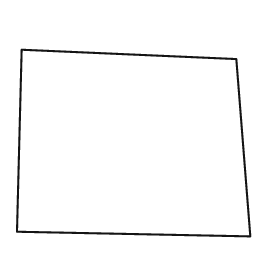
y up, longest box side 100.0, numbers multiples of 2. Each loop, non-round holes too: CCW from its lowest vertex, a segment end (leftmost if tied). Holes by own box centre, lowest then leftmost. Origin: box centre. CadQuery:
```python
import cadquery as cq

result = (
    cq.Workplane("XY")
    .moveTo(50.0, -40.0)
    .lineTo(44.0, 36.0)
    .lineTo(-48.0, 40.0)
    .lineTo(-50.0, -38.0)
    .close()
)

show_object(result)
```